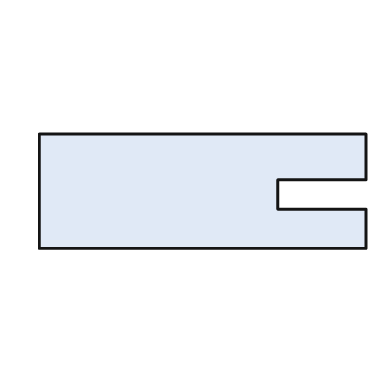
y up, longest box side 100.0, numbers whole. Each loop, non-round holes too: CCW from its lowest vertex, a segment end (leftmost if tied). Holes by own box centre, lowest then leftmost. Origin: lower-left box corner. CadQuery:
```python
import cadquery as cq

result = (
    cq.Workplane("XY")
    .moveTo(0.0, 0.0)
    .lineTo(100.0, 0.0)
    .lineTo(100.0, 12.0)
    .lineTo(73.0, 12.0)
    .lineTo(73.0, 21.0)
    .lineTo(100.0, 21.0)
    .lineTo(100.0, 35.0)
    .lineTo(0.0, 35.0)
    .close()
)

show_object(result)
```